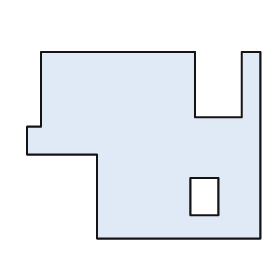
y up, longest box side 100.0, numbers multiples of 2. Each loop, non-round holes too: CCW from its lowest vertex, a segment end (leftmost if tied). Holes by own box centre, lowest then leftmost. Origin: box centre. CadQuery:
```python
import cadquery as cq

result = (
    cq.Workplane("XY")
    .moveTo(-20.0, -40.0)
    .lineTo(50.0, -40.0)
    .lineTo(50.0, 40.0)
    .lineTo(42.0, 40.0)
    .lineTo(42.0, 12.0)
    .lineTo(22.0, 12.0)
    .lineTo(22.0, 40.0)
    .lineTo(-44.0, 40.0)
    .lineTo(-44.0, 8.0)
    .lineTo(-50.0, 8.0)
    .lineTo(-50.0, -4.0)
    .lineTo(-20.0, -4.0)
    .close()
    .moveTo(20.0, -30.0)
    .lineTo(32.0, -30.0)
    .lineTo(32.0, -14.0)
    .lineTo(20.0, -14.0)
    .close()
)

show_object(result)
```